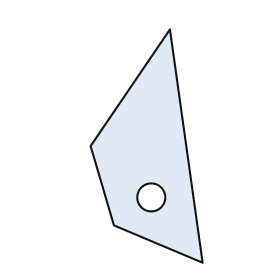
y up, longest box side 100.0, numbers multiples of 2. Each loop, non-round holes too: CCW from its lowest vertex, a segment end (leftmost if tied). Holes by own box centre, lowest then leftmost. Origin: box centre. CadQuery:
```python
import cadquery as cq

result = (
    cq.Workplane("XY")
    .moveTo(24.0, -50.0)
    .lineTo(10.0, 50.0)
    .lineTo(-24.0, 0.0)
    .lineTo(-14.0, -34.0)
    .close()
    .moveTo(2.0, -22.0)
    .circle(6.0)
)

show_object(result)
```